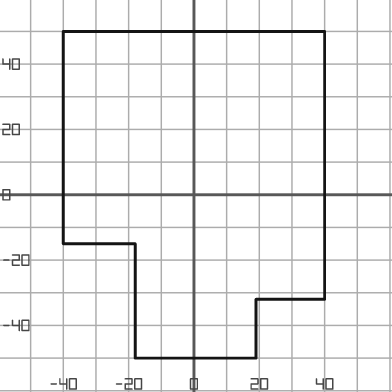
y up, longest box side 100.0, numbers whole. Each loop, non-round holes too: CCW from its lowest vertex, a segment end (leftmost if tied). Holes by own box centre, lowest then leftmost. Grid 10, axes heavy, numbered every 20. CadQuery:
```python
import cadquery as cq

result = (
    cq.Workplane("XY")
    .moveTo(-18.0, -50.0)
    .lineTo(19.0, -50.0)
    .lineTo(19.0, -32.0)
    .lineTo(40.0, -32.0)
    .lineTo(40.0, 50.0)
    .lineTo(-40.0, 50.0)
    .lineTo(-40.0, -15.0)
    .lineTo(-18.0, -15.0)
    .close()
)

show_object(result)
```